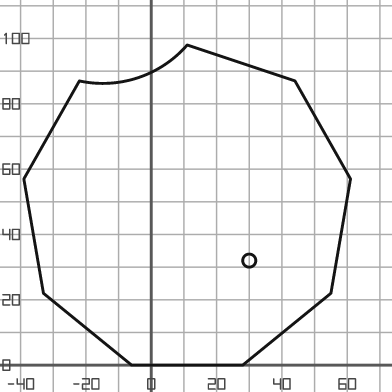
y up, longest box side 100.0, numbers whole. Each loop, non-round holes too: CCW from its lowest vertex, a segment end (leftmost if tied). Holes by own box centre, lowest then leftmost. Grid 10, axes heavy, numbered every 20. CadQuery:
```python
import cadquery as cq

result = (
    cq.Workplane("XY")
    .moveTo(-6.0, 0.0)
    .lineTo(28.0, 0.0)
    .lineTo(55.0, 22.0)
    .lineTo(61.0, 57.0)
    .lineTo(44.0, 87.0)
    .lineTo(11.0, 98.0)
    .threePointArc((-4.0, 88.0), (-22.0, 87.0))
    .lineTo(-39.0, 57.0)
    .lineTo(-33.0, 22.0)
    .close()
    .moveTo(30.0, 32.0)
    .circle(2.0)
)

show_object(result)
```